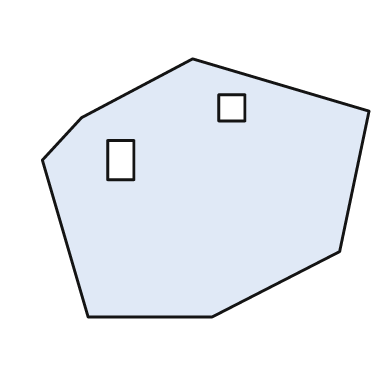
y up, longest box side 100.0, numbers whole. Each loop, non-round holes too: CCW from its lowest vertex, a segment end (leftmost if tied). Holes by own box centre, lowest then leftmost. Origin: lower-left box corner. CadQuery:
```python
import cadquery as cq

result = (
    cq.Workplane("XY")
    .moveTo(14.0, 0.0)
    .lineTo(52.0, 0.0)
    .lineTo(91.0, 20.0)
    .lineTo(100.0, 63.0)
    .lineTo(46.0, 79.0)
    .lineTo(12.0, 61.0)
    .lineTo(0.0, 48.0)
    .close()
    .moveTo(20.0, 42.0)
    .lineTo(28.0, 42.0)
    .lineTo(28.0, 54.0)
    .lineTo(20.0, 54.0)
    .close()
    .moveTo(54.0, 60.0)
    .lineTo(62.0, 60.0)
    .lineTo(62.0, 68.0)
    .lineTo(54.0, 68.0)
    .close()
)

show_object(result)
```